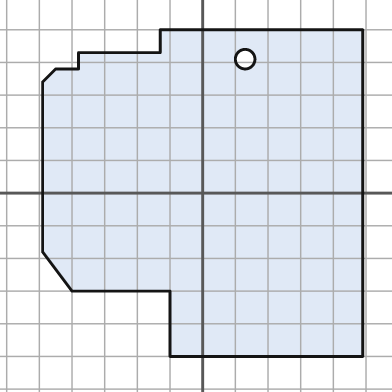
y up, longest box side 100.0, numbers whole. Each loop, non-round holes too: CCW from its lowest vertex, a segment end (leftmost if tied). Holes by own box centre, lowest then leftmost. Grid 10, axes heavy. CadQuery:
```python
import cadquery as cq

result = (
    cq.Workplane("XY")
    .moveTo(-10.0, -50.0)
    .lineTo(49.0, -50.0)
    .lineTo(49.0, 50.0)
    .lineTo(-13.0, 50.0)
    .lineTo(-13.0, 43.0)
    .lineTo(-38.0, 43.0)
    .lineTo(-38.0, 38.0)
    .lineTo(-45.0, 38.0)
    .lineTo(-49.0, 34.0)
    .lineTo(-49.0, -18.0)
    .lineTo(-40.0, -30.0)
    .lineTo(-10.0, -30.0)
    .close()
    .moveTo(13.0, 41.0)
    .circle(3.0)
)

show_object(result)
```